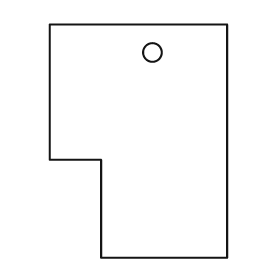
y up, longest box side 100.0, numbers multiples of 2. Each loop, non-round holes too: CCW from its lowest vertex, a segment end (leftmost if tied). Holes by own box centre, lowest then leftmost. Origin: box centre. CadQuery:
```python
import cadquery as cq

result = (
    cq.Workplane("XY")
    .moveTo(-16.0, -50.0)
    .lineTo(38.0, -50.0)
    .lineTo(38.0, 50.0)
    .lineTo(-38.0, 50.0)
    .lineTo(-38.0, -8.0)
    .lineTo(-16.0, -8.0)
    .close()
    .moveTo(6.0, 38.0)
    .circle(4.0)
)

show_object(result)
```